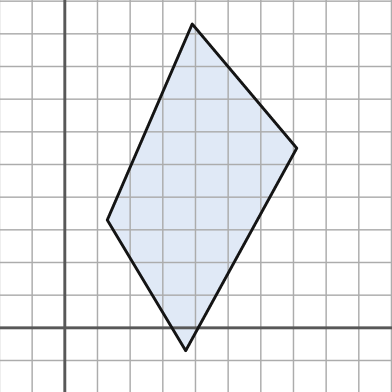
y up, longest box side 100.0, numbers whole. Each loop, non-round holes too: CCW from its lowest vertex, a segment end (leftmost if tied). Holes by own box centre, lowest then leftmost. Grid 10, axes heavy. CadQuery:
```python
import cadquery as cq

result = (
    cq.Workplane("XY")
    .moveTo(37.0, -7.0)
    .lineTo(71.0, 55.0)
    .lineTo(39.0, 93.0)
    .lineTo(13.0, 33.0)
    .close()
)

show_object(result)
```